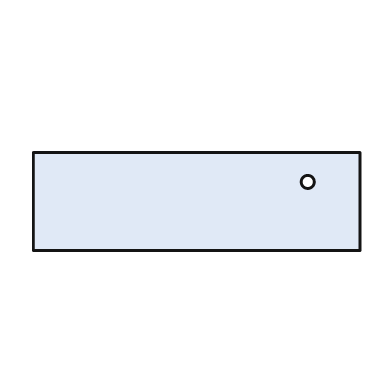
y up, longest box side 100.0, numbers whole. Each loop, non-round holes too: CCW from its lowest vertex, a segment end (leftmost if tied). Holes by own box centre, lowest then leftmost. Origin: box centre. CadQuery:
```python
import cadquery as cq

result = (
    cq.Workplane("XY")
    .moveTo(-50.0, -15.0)
    .lineTo(50.0, -15.0)
    .lineTo(50.0, 15.0)
    .lineTo(-50.0, 15.0)
    .close()
    .moveTo(34.0, 6.0)
    .circle(2.0)
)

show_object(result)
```